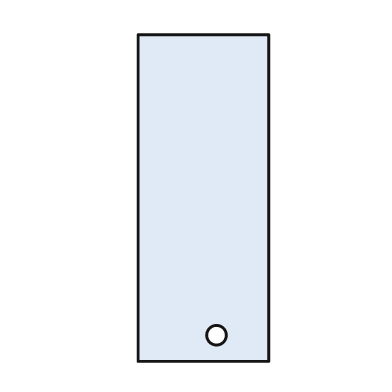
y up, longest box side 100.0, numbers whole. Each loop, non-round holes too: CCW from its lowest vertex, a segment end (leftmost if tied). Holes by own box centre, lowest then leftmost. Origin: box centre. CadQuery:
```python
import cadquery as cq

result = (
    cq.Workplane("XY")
    .moveTo(-20.0, -50.0)
    .lineTo(20.0, -50.0)
    .lineTo(20.0, 50.0)
    .lineTo(-20.0, 50.0)
    .close()
    .moveTo(4.0, -42.0)
    .circle(3.0)
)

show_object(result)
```